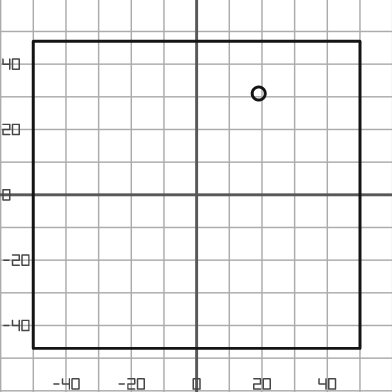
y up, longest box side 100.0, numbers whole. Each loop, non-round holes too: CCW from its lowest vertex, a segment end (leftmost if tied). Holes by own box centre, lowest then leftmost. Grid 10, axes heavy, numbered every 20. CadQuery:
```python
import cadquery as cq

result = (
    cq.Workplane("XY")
    .moveTo(-50.0, -47.0)
    .lineTo(50.0, -47.0)
    .lineTo(50.0, 47.0)
    .lineTo(-50.0, 47.0)
    .close()
    .moveTo(19.0, 31.0)
    .circle(2.0)
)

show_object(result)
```